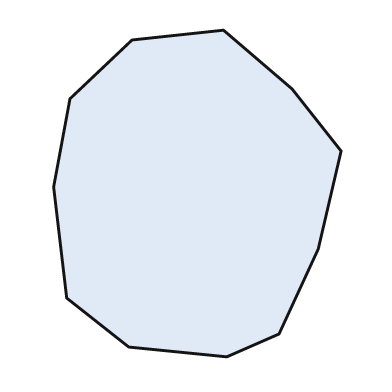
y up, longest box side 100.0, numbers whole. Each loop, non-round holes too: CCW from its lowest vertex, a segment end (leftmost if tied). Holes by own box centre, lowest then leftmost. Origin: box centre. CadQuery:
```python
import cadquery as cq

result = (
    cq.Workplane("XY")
    .moveTo(9.0, -50.0)
    .lineTo(25.0, -43.0)
    .lineTo(37.0, -17.0)
    .lineTo(44.0, 13.0)
    .lineTo(29.0, 32.0)
    .lineTo(8.0, 50.0)
    .lineTo(-20.0, 47.0)
    .lineTo(-39.0, 29.0)
    .lineTo(-44.0, 2.0)
    .lineTo(-40.0, -32.0)
    .lineTo(-21.0, -47.0)
    .close()
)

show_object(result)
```